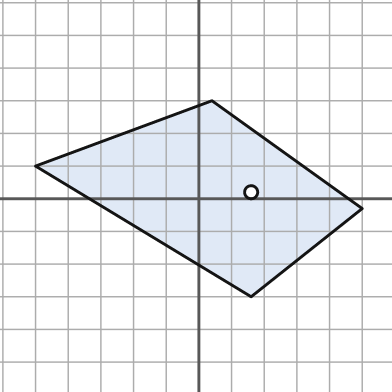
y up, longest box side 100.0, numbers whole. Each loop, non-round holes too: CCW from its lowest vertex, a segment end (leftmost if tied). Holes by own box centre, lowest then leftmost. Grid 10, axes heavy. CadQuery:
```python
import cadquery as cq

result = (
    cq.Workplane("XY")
    .moveTo(16.0, -30.0)
    .lineTo(50.0, -3.0)
    .lineTo(4.0, 30.0)
    .lineTo(-50.0, 10.0)
    .close()
    .moveTo(16.0, 2.0)
    .circle(2.0)
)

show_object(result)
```